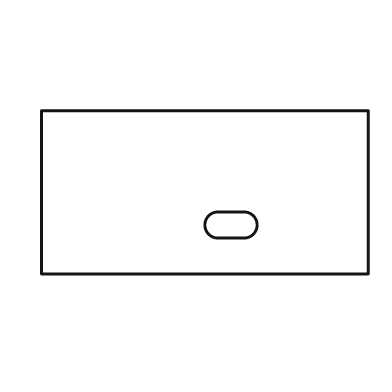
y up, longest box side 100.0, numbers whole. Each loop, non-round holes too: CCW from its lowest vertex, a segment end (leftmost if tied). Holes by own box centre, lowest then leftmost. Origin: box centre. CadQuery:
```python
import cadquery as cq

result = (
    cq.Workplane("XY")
    .moveTo(-50.0, -25.0)
    .lineTo(50.0, -25.0)
    .lineTo(50.0, 25.0)
    .lineTo(-50.0, 25.0)
    .close()
    .moveTo(4.0, -14.0)
    .lineTo(12.0, -14.0)
    .threePointArc((16.0, -10.0), (12.0, -6.0))
    .lineTo(4.0, -6.0)
    .threePointArc((0.0, -10.0), (4.0, -14.0))
    .close()
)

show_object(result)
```